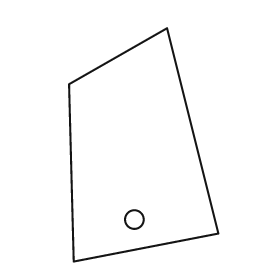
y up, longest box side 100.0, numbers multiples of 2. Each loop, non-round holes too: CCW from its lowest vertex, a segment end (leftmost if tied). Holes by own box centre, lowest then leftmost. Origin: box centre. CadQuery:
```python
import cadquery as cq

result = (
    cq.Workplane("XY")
    .moveTo(-30.0, -50.0)
    .lineTo(32.0, -38.0)
    .lineTo(10.0, 50.0)
    .lineTo(-32.0, 26.0)
    .close()
    .moveTo(-4.0, -32.0)
    .circle(4.0)
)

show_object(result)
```